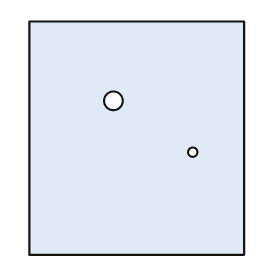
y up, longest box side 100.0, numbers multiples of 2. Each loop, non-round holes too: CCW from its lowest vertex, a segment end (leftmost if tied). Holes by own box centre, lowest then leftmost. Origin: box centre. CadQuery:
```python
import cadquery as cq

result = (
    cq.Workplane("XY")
    .moveTo(-46.0, -50.0)
    .lineTo(46.0, -50.0)
    .lineTo(46.0, 50.0)
    .lineTo(-46.0, 50.0)
    .close()
    .moveTo(24.0, -6.0)
    .circle(2.0)
    .moveTo(-10.0, 16.0)
    .circle(4.0)
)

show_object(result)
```